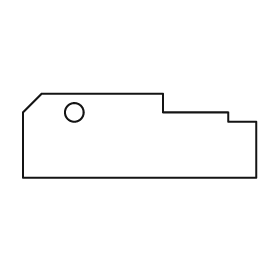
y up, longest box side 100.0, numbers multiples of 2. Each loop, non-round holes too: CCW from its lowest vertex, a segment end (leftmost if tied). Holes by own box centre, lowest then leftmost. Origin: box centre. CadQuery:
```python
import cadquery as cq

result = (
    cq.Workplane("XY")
    .moveTo(-50.0, -18.0)
    .lineTo(50.0, -18.0)
    .lineTo(50.0, 6.0)
    .lineTo(38.0, 6.0)
    .lineTo(38.0, 10.0)
    .lineTo(10.0, 10.0)
    .lineTo(10.0, 18.0)
    .lineTo(-42.0, 18.0)
    .lineTo(-50.0, 10.0)
    .close()
    .moveTo(-28.0, 10.0)
    .circle(4.0)
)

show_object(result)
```